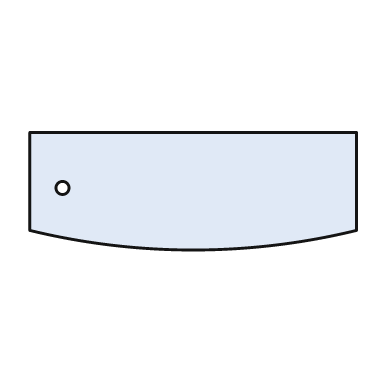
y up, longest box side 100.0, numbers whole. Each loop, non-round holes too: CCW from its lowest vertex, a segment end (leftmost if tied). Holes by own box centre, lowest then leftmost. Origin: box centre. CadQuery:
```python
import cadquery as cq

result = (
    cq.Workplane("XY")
    .moveTo(-50.0, -12.0)
    .threePointArc((0.0, -18.0), (50.0, -12.0))
    .lineTo(50.0, 18.0)
    .lineTo(-50.0, 18.0)
    .close()
    .moveTo(-40.0, 1.0)
    .circle(2.0)
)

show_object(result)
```